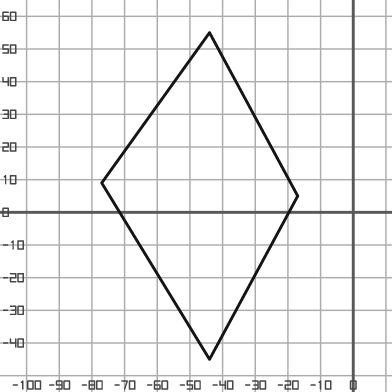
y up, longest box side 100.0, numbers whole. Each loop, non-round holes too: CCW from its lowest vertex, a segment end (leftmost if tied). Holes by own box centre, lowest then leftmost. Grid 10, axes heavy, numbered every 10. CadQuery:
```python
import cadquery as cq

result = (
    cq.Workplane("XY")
    .moveTo(-44.0, -45.0)
    .lineTo(-17.0, 5.0)
    .lineTo(-44.0, 55.0)
    .lineTo(-77.0, 9.0)
    .close()
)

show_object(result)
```